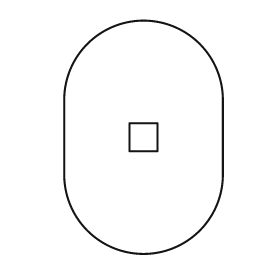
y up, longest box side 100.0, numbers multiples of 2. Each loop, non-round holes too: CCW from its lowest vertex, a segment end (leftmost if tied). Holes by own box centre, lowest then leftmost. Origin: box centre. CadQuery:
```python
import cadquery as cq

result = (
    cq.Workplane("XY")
    .moveTo(-34.0, -16.0)
    .threePointArc((0.0, -50.0), (34.0, -16.0))
    .lineTo(34.0, 16.0)
    .threePointArc((0.0, 50.0), (-34.0, 16.0))
    .close()
    .moveTo(-6.0, -6.0)
    .lineTo(6.0, -6.0)
    .lineTo(6.0, 6.0)
    .lineTo(-6.0, 6.0)
    .close()
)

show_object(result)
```